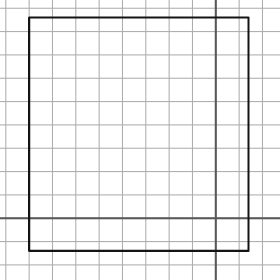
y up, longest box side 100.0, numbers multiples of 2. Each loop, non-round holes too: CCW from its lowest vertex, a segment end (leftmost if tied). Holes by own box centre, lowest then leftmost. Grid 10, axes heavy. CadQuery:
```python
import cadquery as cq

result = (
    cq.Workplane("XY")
    .moveTo(-80.0, -14.0)
    .lineTo(14.0, -14.0)
    .lineTo(14.0, 86.0)
    .lineTo(-80.0, 86.0)
    .close()
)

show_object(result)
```